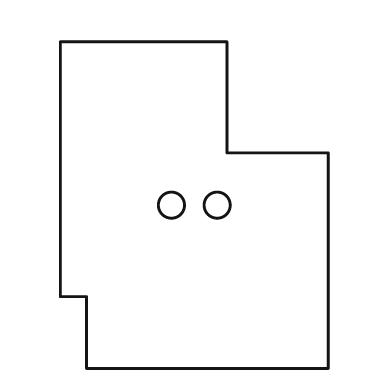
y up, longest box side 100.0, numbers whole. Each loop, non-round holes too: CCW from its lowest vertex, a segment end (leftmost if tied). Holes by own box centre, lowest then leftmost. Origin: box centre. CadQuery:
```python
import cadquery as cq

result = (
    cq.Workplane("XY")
    .moveTo(-33.0, -50.0)
    .lineTo(41.0, -50.0)
    .lineTo(41.0, 16.0)
    .lineTo(10.0, 16.0)
    .lineTo(10.0, 50.0)
    .lineTo(-41.0, 50.0)
    .lineTo(-41.0, -28.0)
    .lineTo(-33.0, -28.0)
    .close()
    .moveTo(-7.0, 0.0)
    .circle(4.0)
    .moveTo(7.0, 0.0)
    .circle(4.0)
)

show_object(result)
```